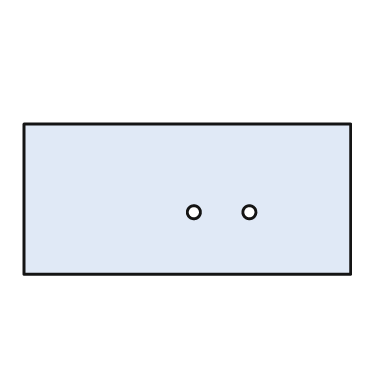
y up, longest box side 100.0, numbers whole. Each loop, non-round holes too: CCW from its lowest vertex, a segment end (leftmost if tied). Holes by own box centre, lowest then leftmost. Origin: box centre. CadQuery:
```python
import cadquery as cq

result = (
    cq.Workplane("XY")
    .moveTo(-50.0, -23.0)
    .lineTo(50.0, -23.0)
    .lineTo(50.0, 23.0)
    .lineTo(-50.0, 23.0)
    .close()
    .moveTo(2.0, -4.0)
    .circle(2.0)
    .moveTo(19.0, -4.0)
    .circle(2.0)
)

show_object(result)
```